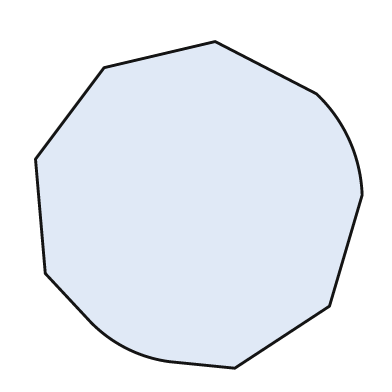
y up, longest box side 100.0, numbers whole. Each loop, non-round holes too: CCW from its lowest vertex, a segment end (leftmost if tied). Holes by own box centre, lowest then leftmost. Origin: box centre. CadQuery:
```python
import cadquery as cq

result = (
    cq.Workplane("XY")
    .moveTo(11.0, -50.0)
    .lineTo(40.0, -31.0)
    .lineTo(50.0, 3.0)
    .threePointArc((46.0, 20.0), (36.0, 34.0))
    .lineTo(5.0, 50.0)
    .lineTo(-29.0, 42.0)
    .lineTo(-50.0, 14.0)
    .lineTo(-47.0, -21.0)
    .lineTo(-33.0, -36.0)
    .threePointArc((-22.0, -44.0), (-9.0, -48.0))
    .close()
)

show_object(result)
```